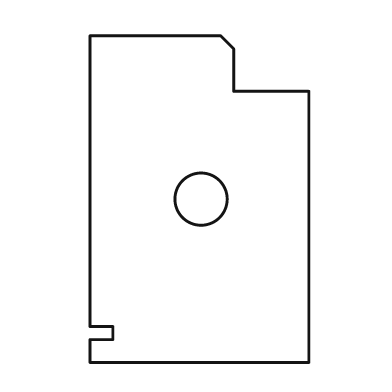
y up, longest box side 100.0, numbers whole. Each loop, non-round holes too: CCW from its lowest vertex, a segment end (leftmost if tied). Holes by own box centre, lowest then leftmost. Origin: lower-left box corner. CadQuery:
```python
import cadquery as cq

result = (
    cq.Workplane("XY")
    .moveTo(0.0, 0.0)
    .lineTo(67.0, 0.0)
    .lineTo(67.0, 83.0)
    .lineTo(44.0, 83.0)
    .lineTo(44.0, 96.0)
    .lineTo(40.0, 100.0)
    .lineTo(0.0, 100.0)
    .lineTo(0.0, 11.0)
    .lineTo(7.0, 11.0)
    .lineTo(7.0, 7.0)
    .lineTo(0.0, 7.0)
    .close()
    .moveTo(34.0, 50.0)
    .circle(8.0)
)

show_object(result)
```